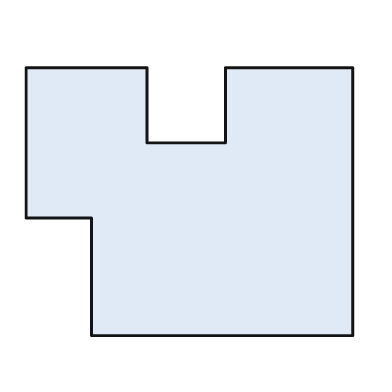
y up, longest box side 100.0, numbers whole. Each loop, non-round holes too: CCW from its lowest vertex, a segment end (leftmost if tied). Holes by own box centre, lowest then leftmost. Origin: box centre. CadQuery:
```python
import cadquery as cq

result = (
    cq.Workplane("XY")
    .moveTo(-30.0, -41.0)
    .lineTo(50.0, -41.0)
    .lineTo(50.0, 41.0)
    .lineTo(11.0, 41.0)
    .lineTo(11.0, 18.0)
    .lineTo(-13.0, 18.0)
    .lineTo(-13.0, 41.0)
    .lineTo(-50.0, 41.0)
    .lineTo(-50.0, -5.0)
    .lineTo(-30.0, -5.0)
    .close()
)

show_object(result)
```